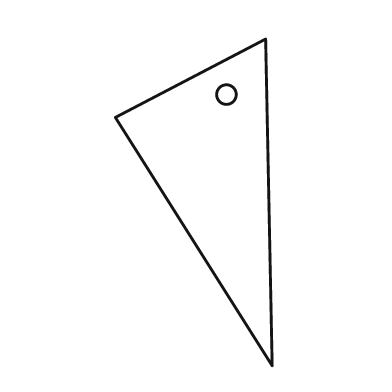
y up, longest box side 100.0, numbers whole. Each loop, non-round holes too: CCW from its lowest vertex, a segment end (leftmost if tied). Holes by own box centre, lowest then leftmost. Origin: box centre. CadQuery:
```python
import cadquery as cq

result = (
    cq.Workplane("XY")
    .moveTo(24.0, -50.0)
    .lineTo(22.0, 50.0)
    .lineTo(-24.0, 26.0)
    .close()
    .moveTo(10.0, 33.0)
    .circle(3.0)
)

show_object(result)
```